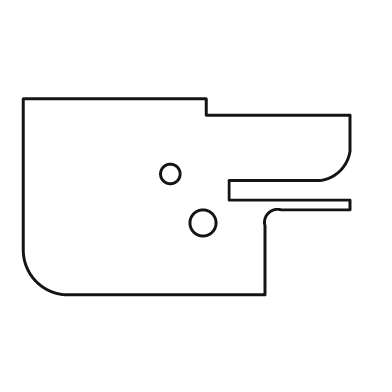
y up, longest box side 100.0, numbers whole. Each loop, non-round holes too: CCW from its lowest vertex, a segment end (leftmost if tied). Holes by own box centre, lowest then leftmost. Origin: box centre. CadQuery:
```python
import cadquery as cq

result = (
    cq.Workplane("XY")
    .moveTo(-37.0, -30.0)
    .lineTo(24.0, -30.0)
    .lineTo(24.0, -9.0)
    .threePointArc((25.0, -5.0), (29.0, -4.0))
    .lineTo(50.0, -4.0)
    .lineTo(50.0, -1.0)
    .lineTo(13.0, -1.0)
    .lineTo(13.0, 5.0)
    .lineTo(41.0, 5.0)
    .threePointArc((47.0, 8.0), (50.0, 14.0))
    .lineTo(50.0, 25.0)
    .lineTo(6.0, 25.0)
    .lineTo(6.0, 30.0)
    .lineTo(-50.0, 30.0)
    .lineTo(-50.0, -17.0)
    .threePointArc((-46.0, -26.0), (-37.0, -30.0))
    .close()
    .moveTo(5.0, -8.0)
    .circle(4.0)
    .moveTo(-5.0, 7.0)
    .circle(3.0)
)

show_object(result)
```